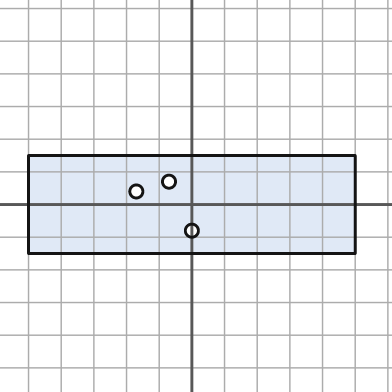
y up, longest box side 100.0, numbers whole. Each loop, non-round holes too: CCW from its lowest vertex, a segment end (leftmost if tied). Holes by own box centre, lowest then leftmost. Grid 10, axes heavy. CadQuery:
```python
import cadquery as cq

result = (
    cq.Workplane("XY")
    .moveTo(-50.0, -15.0)
    .lineTo(50.0, -15.0)
    .lineTo(50.0, 15.0)
    .lineTo(-50.0, 15.0)
    .close()
    .moveTo(0.0, -8.0)
    .circle(2.0)
    .moveTo(-17.0, 4.0)
    .circle(2.0)
    .moveTo(-7.0, 7.0)
    .circle(2.0)
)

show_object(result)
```